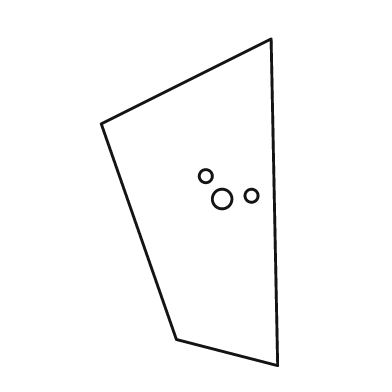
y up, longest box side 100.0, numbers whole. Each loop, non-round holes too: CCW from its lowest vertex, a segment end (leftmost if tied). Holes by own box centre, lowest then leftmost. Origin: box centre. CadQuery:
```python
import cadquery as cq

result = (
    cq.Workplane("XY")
    .moveTo(27.0, -50.0)
    .lineTo(25.0, 50.0)
    .lineTo(-27.0, 24.0)
    .lineTo(-4.0, -42.0)
    .close()
    .moveTo(10.0, 1.0)
    .circle(3.0)
    .moveTo(19.0, 2.0)
    .circle(2.0)
    .moveTo(5.0, 8.0)
    .circle(2.0)
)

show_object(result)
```